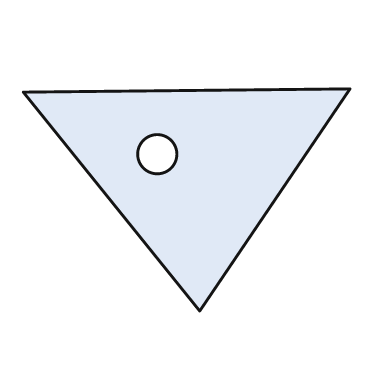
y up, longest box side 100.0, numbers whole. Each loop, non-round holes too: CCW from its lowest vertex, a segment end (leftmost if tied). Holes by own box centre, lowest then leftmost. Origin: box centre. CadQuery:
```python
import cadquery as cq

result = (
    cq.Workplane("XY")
    .moveTo(4.0, -34.0)
    .lineTo(50.0, 34.0)
    .lineTo(-50.0, 33.0)
    .close()
    .moveTo(-9.0, 14.0)
    .circle(6.0)
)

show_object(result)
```